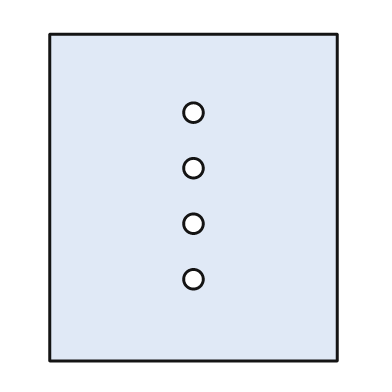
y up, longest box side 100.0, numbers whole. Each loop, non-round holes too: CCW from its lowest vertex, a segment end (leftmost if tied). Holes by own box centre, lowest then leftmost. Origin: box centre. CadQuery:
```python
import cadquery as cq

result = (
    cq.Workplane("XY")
    .moveTo(-44.0, -50.0)
    .lineTo(44.0, -50.0)
    .lineTo(44.0, 50.0)
    .lineTo(-44.0, 50.0)
    .close()
    .moveTo(0.0, -25.0)
    .circle(3.0)
    .moveTo(0.0, -8.0)
    .circle(3.0)
    .moveTo(0.0, 9.0)
    .circle(3.0)
    .moveTo(0.0, 26.0)
    .circle(3.0)
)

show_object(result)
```